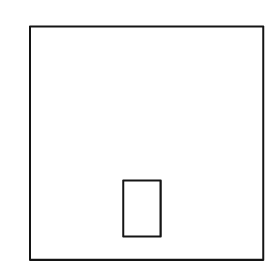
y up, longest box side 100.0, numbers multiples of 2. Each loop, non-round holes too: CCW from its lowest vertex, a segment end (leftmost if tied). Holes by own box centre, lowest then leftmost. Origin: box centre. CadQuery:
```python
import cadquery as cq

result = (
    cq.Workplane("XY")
    .moveTo(-50.0, -50.0)
    .lineTo(50.0, -50.0)
    .lineTo(50.0, 50.0)
    .lineTo(-50.0, 50.0)
    .close()
    .moveTo(-10.0, -40.0)
    .lineTo(6.0, -40.0)
    .lineTo(6.0, -16.0)
    .lineTo(-10.0, -16.0)
    .close()
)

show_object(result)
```